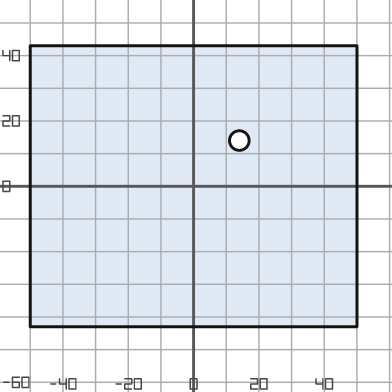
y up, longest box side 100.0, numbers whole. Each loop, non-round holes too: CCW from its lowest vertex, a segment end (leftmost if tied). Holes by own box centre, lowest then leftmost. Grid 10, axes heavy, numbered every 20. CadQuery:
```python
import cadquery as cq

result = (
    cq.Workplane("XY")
    .moveTo(-50.0, -43.0)
    .lineTo(50.0, -43.0)
    .lineTo(50.0, 43.0)
    .lineTo(-50.0, 43.0)
    .close()
    .moveTo(14.0, 14.0)
    .circle(3.0)
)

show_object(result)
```